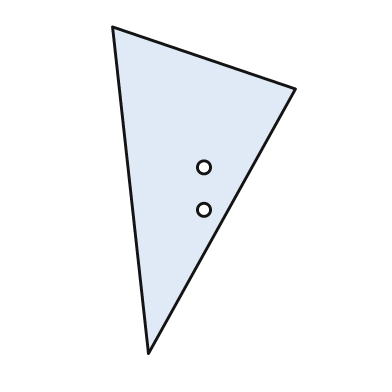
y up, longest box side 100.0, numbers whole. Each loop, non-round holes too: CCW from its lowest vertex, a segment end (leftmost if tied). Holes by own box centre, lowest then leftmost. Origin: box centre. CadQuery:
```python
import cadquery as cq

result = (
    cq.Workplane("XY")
    .moveTo(-17.0, -50.0)
    .lineTo(28.0, 31.0)
    .lineTo(-28.0, 50.0)
    .close()
    .moveTo(0.0, -6.0)
    .circle(2.0)
    .moveTo(0.0, 7.0)
    .circle(2.0)
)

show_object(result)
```